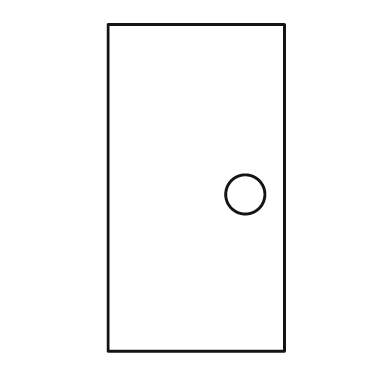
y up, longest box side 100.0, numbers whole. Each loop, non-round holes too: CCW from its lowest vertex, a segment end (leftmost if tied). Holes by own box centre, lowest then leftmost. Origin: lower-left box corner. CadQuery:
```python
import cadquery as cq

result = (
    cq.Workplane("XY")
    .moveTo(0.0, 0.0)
    .lineTo(54.0, 0.0)
    .lineTo(54.0, 100.0)
    .lineTo(0.0, 100.0)
    .close()
    .moveTo(42.0, 48.0)
    .circle(6.0)
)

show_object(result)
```